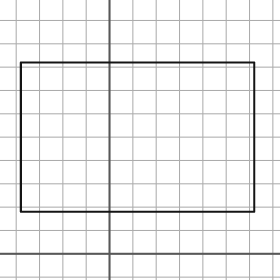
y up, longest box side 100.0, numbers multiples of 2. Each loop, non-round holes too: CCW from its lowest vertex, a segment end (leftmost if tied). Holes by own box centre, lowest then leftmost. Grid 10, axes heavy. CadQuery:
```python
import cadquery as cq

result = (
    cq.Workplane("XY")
    .moveTo(-38.0, 18.0)
    .lineTo(62.0, 18.0)
    .lineTo(62.0, 82.0)
    .lineTo(-38.0, 82.0)
    .close()
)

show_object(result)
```